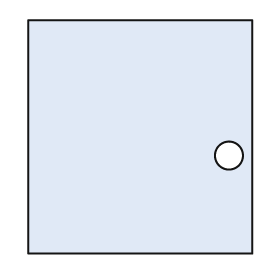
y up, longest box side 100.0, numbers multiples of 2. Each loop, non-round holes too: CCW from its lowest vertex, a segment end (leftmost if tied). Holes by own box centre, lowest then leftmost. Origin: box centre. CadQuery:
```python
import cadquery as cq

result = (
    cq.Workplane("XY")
    .moveTo(-48.0, -50.0)
    .lineTo(48.0, -50.0)
    .lineTo(48.0, 50.0)
    .lineTo(-48.0, 50.0)
    .close()
    .moveTo(38.0, -8.0)
    .circle(6.0)
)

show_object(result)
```